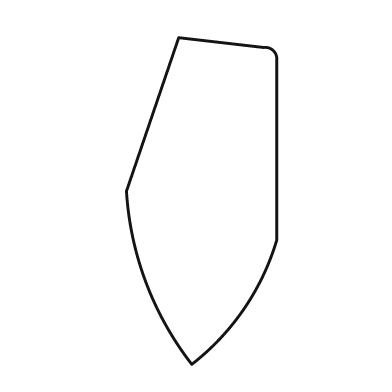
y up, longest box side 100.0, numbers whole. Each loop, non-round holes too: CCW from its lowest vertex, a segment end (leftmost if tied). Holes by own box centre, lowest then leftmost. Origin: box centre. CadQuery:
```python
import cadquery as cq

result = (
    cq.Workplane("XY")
    .moveTo(-3.0, -50.0)
    .threePointArc((13.0, -33.0), (23.0, -12.0))
    .lineTo(23.0, 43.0)
    .threePointArc((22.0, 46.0), (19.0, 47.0))
    .lineTo(-7.0, 50.0)
    .lineTo(-23.0, 3.0)
    .threePointArc((-17.0, -25.0), (-3.0, -50.0))
    .close()
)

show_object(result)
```